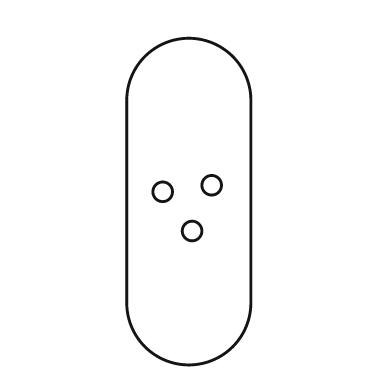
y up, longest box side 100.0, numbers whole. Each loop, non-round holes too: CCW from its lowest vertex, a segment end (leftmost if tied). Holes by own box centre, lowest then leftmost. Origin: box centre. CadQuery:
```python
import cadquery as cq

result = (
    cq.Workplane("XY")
    .moveTo(-19.0, -31.0)
    .threePointArc((0.0, -50.0), (19.0, -31.0))
    .lineTo(19.0, 31.0)
    .threePointArc((0.0, 50.0), (-19.0, 31.0))
    .close()
    .moveTo(1.0, -9.0)
    .circle(3.0)
    .moveTo(-8.0, 3.0)
    .circle(3.0)
    .moveTo(7.0, 5.0)
    .circle(3.0)
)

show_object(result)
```